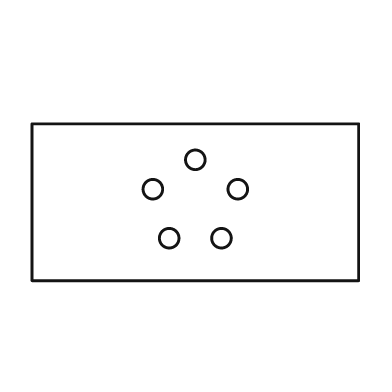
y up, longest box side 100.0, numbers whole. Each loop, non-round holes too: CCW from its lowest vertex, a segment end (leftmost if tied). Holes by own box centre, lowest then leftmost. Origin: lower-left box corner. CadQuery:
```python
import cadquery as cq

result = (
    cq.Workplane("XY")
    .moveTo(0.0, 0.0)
    .lineTo(100.0, 0.0)
    .lineTo(100.0, 48.0)
    .lineTo(0.0, 48.0)
    .close()
    .moveTo(42.0, 13.0)
    .circle(3.0)
    .moveTo(58.0, 13.0)
    .circle(3.0)
    .moveTo(37.0, 28.0)
    .circle(3.0)
    .moveTo(63.0, 28.0)
    .circle(3.0)
    .moveTo(50.0, 37.0)
    .circle(3.0)
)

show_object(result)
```